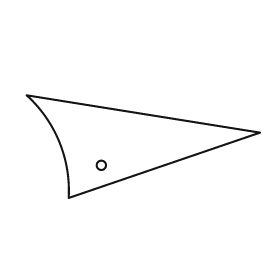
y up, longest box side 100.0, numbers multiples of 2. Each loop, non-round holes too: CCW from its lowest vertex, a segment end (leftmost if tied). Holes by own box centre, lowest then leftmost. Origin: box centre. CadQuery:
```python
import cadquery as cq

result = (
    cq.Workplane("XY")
    .moveTo(-32.0, -22.0)
    .lineTo(50.0, 6.0)
    .lineTo(-50.0, 22.0)
    .threePointArc((-36.0, 2.0), (-32.0, -22.0))
    .close()
    .moveTo(-18.0, -8.0)
    .circle(2.0)
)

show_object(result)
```